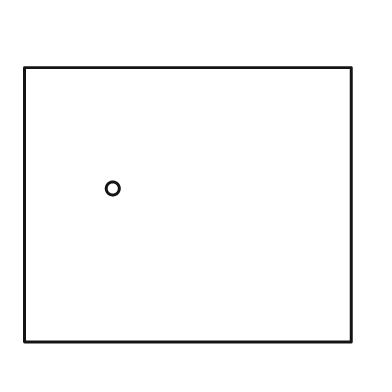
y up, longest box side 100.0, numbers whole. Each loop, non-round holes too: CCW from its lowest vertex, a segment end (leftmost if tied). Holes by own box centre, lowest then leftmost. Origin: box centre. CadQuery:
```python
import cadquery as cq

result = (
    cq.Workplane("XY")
    .moveTo(-50.0, -42.0)
    .lineTo(50.0, -42.0)
    .lineTo(50.0, 42.0)
    .lineTo(-50.0, 42.0)
    .close()
    .moveTo(-23.0, 5.0)
    .circle(2.0)
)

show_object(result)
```